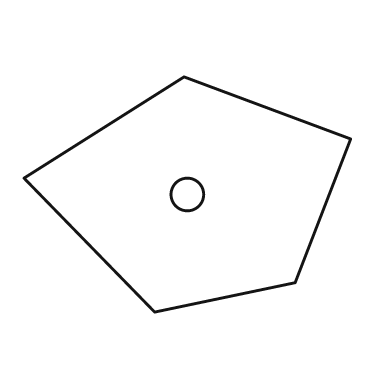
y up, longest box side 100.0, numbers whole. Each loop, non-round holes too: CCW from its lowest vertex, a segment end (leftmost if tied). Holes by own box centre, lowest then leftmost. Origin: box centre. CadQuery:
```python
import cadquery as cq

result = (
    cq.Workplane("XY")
    .moveTo(-10.0, -36.0)
    .lineTo(33.0, -27.0)
    .lineTo(50.0, 17.0)
    .lineTo(-1.0, 36.0)
    .lineTo(-50.0, 5.0)
    .close()
    .moveTo(0.0, 0.0)
    .circle(5.0)
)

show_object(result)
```